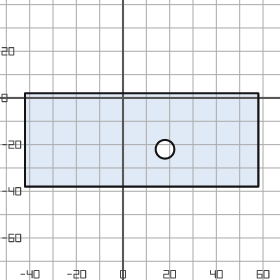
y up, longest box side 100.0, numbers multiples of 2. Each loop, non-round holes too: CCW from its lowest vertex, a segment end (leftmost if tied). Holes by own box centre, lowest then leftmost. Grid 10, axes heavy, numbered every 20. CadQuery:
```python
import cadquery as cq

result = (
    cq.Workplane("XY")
    .moveTo(-42.0, -38.0)
    .lineTo(58.0, -38.0)
    .lineTo(58.0, 2.0)
    .lineTo(-42.0, 2.0)
    .close()
    .moveTo(18.0, -22.0)
    .circle(4.0)
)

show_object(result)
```